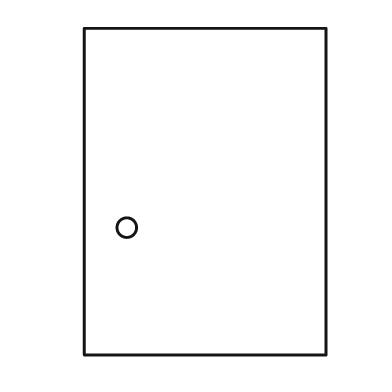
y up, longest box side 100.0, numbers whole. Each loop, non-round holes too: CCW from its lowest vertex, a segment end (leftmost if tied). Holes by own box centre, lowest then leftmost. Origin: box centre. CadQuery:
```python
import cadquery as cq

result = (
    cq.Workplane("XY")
    .moveTo(-37.0, -50.0)
    .lineTo(37.0, -50.0)
    .lineTo(37.0, 50.0)
    .lineTo(-37.0, 50.0)
    .close()
    .moveTo(-24.0, -11.0)
    .circle(3.0)
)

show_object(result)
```